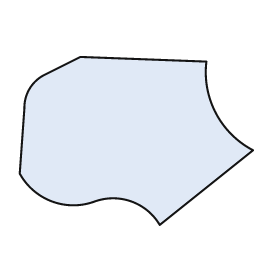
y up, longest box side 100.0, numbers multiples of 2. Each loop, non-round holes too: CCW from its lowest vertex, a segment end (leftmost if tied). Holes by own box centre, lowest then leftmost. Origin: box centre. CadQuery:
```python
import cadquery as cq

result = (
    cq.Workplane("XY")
    .moveTo(10.0, -36.0)
    .lineTo(50.0, -4.0)
    .threePointArc((34.0, 12.0), (30.0, 34.0))
    .lineTo(-24.0, 36.0)
    .lineTo(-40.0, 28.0)
    .threePointArc((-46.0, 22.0), (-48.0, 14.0))
    .lineTo(-50.0, -14.0)
    .threePointArc((-36.0, -26.0), (-18.0, -26.0))
    .threePointArc((-2.0, -26.0), (10.0, -36.0))
    .close()
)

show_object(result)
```